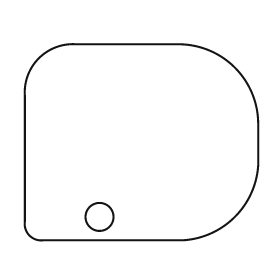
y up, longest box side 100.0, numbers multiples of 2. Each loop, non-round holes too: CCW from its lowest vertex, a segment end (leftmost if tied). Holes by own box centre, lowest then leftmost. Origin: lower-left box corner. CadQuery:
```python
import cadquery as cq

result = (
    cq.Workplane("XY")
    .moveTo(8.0, 0.0)
    .lineTo(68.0, 0.0)
    .threePointArc((90.0, 10.0), (100.0, 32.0))
    .lineTo(100.0, 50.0)
    .threePointArc((90.0, 74.0), (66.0, 84.0))
    .lineTo(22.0, 84.0)
    .threePointArc((6.0, 78.0), (0.0, 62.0))
    .lineTo(0.0, 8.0)
    .threePointArc((2.0, 2.0), (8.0, 0.0))
    .close()
    .moveTo(32.0, 10.0)
    .circle(6.0)
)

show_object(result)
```